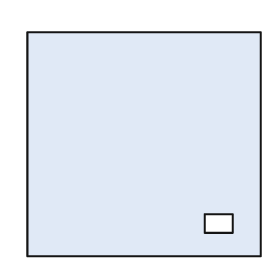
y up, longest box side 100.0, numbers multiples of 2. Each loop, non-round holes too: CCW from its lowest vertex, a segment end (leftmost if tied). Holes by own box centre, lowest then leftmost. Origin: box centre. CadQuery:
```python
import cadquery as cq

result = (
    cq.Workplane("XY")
    .moveTo(-50.0, -48.0)
    .lineTo(50.0, -48.0)
    .lineTo(50.0, 48.0)
    .lineTo(-50.0, 48.0)
    .close()
    .moveTo(26.0, -38.0)
    .lineTo(38.0, -38.0)
    .lineTo(38.0, -30.0)
    .lineTo(26.0, -30.0)
    .close()
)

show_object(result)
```